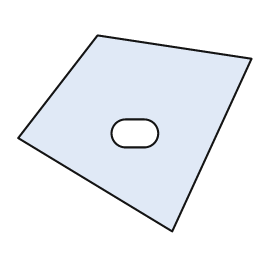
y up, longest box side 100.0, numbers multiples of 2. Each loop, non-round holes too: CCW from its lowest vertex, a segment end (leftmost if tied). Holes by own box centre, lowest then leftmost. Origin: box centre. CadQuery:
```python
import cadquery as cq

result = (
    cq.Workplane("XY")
    .moveTo(16.0, -42.0)
    .lineTo(50.0, 32.0)
    .lineTo(-16.0, 42.0)
    .lineTo(-50.0, -2.0)
    .close()
    .moveTo(-4.0, -6.0)
    .lineTo(4.0, -6.0)
    .threePointArc((10.0, 0.0), (4.0, 6.0))
    .lineTo(-4.0, 6.0)
    .threePointArc((-10.0, 0.0), (-4.0, -6.0))
    .close()
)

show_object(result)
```